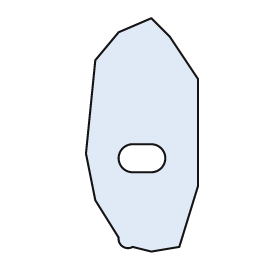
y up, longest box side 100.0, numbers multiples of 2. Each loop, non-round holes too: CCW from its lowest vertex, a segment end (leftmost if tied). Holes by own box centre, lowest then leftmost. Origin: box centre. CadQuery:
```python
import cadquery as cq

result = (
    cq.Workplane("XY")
    .moveTo(4.0, -50.0)
    .lineTo(16.0, -48.0)
    .lineTo(24.0, -22.0)
    .lineTo(24.0, 24.0)
    .lineTo(12.0, 42.0)
    .lineTo(4.0, 50.0)
    .lineTo(-10.0, 44.0)
    .lineTo(-20.0, 32.0)
    .lineTo(-24.0, -8.0)
    .lineTo(-20.0, -28.0)
    .lineTo(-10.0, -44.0)
    .threePointArc((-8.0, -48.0), (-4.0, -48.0))
    .close()
    .moveTo(-4.0, -16.0)
    .lineTo(4.0, -16.0)
    .threePointArc((10.0, -10.0), (4.0, -4.0))
    .lineTo(-4.0, -4.0)
    .threePointArc((-10.0, -10.0), (-4.0, -16.0))
    .close()
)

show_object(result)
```